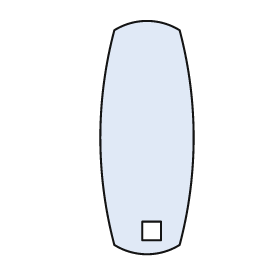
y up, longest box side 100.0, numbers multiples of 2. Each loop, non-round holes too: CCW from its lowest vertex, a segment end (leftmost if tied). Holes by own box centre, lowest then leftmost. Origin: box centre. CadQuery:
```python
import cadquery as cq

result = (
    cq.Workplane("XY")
    .moveTo(-14.0, -46.0)
    .threePointArc((0.0, -50.0), (14.0, -46.0))
    .threePointArc((20.0, 0.0), (14.0, 46.0))
    .threePointArc((0.0, 50.0), (-14.0, 46.0))
    .threePointArc((-20.0, 0.0), (-14.0, -46.0))
    .close()
    .moveTo(-2.0, -44.0)
    .lineTo(6.0, -44.0)
    .lineTo(6.0, -36.0)
    .lineTo(-2.0, -36.0)
    .close()
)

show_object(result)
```